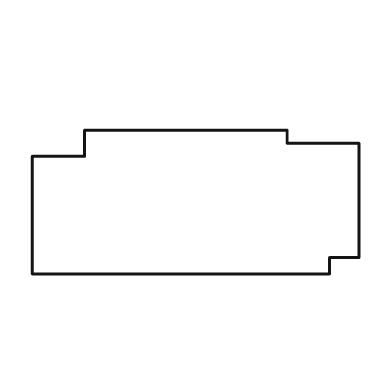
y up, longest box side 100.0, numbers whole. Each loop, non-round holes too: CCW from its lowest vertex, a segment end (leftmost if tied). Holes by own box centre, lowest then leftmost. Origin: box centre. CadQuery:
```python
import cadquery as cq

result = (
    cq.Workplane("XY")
    .moveTo(-50.0, -22.0)
    .lineTo(41.0, -22.0)
    .lineTo(41.0, -17.0)
    .lineTo(50.0, -17.0)
    .lineTo(50.0, 18.0)
    .lineTo(28.0, 18.0)
    .lineTo(28.0, 22.0)
    .lineTo(-34.0, 22.0)
    .lineTo(-34.0, 14.0)
    .lineTo(-50.0, 14.0)
    .close()
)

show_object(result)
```